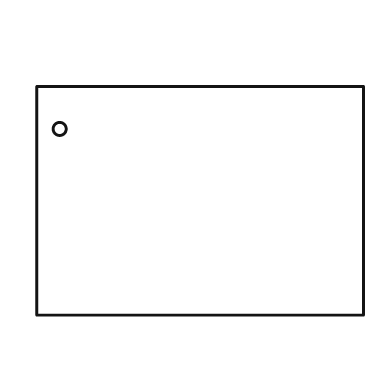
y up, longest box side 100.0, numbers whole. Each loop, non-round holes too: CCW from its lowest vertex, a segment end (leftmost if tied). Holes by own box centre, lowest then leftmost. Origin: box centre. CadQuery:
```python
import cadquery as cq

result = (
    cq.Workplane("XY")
    .moveTo(-50.0, -35.0)
    .lineTo(50.0, -35.0)
    .lineTo(50.0, 35.0)
    .lineTo(-50.0, 35.0)
    .close()
    .moveTo(-43.0, 22.0)
    .circle(2.0)
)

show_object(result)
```